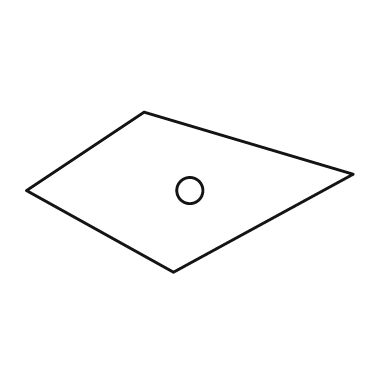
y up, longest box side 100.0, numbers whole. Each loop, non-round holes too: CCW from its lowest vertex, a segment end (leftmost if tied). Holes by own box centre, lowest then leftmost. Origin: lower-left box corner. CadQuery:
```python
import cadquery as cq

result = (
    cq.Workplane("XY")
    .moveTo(45.0, 0.0)
    .lineTo(100.0, 30.0)
    .lineTo(36.0, 49.0)
    .lineTo(0.0, 25.0)
    .close()
    .moveTo(50.0, 25.0)
    .circle(4.0)
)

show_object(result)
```